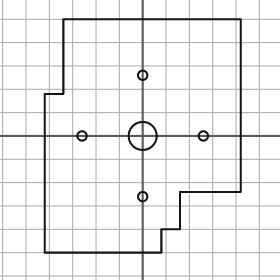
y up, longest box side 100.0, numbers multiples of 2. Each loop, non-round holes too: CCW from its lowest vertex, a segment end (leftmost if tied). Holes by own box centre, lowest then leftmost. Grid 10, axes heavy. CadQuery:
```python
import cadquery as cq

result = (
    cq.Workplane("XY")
    .moveTo(-42.0, -50.0)
    .lineTo(8.0, -50.0)
    .lineTo(8.0, -40.0)
    .lineTo(16.0, -40.0)
    .lineTo(16.0, -24.0)
    .lineTo(42.0, -24.0)
    .lineTo(42.0, 50.0)
    .lineTo(-34.0, 50.0)
    .lineTo(-34.0, 18.0)
    .lineTo(-42.0, 18.0)
    .close()
    .moveTo(0.0, -26.0)
    .circle(2.0)
    .moveTo(-26.0, 0.0)
    .circle(2.0)
    .moveTo(0.0, 0.0)
    .circle(6.0)
    .moveTo(26.0, 0.0)
    .circle(2.0)
    .moveTo(0.0, 26.0)
    .circle(2.0)
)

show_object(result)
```